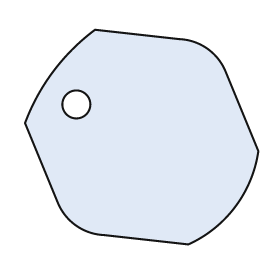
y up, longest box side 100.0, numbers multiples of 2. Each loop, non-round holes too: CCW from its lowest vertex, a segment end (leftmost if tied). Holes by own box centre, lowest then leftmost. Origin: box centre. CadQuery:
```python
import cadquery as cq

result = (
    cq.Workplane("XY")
    .moveTo(20.0, -46.0)
    .threePointArc((40.0, -30.0), (50.0, -6.0))
    .lineTo(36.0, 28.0)
    .threePointArc((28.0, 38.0), (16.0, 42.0))
    .lineTo(-20.0, 46.0)
    .threePointArc((-38.0, 28.0), (-50.0, 6.0))
    .lineTo(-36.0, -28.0)
    .threePointArc((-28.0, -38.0), (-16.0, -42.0))
    .close()
    .moveTo(-28.0, 14.0)
    .circle(6.0)
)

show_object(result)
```